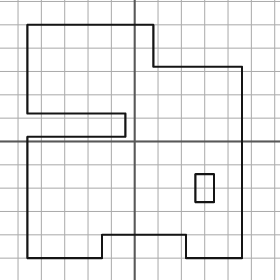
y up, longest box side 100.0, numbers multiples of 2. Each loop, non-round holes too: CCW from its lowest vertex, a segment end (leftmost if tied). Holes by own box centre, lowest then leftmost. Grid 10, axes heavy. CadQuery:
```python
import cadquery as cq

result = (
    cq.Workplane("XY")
    .moveTo(-46.0, -50.0)
    .lineTo(-14.0, -50.0)
    .lineTo(-14.0, -40.0)
    .lineTo(22.0, -40.0)
    .lineTo(22.0, -50.0)
    .lineTo(46.0, -50.0)
    .lineTo(46.0, 32.0)
    .lineTo(8.0, 32.0)
    .lineTo(8.0, 50.0)
    .lineTo(-46.0, 50.0)
    .lineTo(-46.0, 12.0)
    .lineTo(-4.0, 12.0)
    .lineTo(-4.0, 2.0)
    .lineTo(-46.0, 2.0)
    .close()
    .moveTo(26.0, -26.0)
    .lineTo(34.0, -26.0)
    .lineTo(34.0, -14.0)
    .lineTo(26.0, -14.0)
    .close()
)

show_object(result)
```